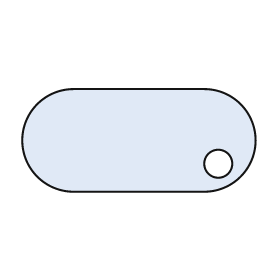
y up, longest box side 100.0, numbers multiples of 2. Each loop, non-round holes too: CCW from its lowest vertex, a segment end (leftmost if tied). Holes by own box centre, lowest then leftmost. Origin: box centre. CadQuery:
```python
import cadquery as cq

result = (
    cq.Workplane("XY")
    .moveTo(-28.0, -22.0)
    .lineTo(28.0, -22.0)
    .threePointArc((50.0, 0.0), (28.0, 22.0))
    .lineTo(-28.0, 22.0)
    .threePointArc((-50.0, 0.0), (-28.0, -22.0))
    .close()
    .moveTo(34.0, -10.0)
    .circle(6.0)
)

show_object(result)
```